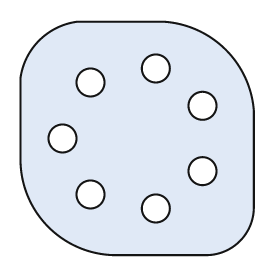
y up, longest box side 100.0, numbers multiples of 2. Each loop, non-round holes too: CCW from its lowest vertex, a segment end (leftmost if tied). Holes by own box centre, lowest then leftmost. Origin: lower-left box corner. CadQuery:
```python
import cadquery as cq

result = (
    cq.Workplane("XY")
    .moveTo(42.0, 0.0)
    .lineTo(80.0, 0.0)
    .threePointArc((94.0, 6.0), (100.0, 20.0))
    .lineTo(100.0, 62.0)
    .threePointArc((88.0, 88.0), (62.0, 100.0))
    .lineTo(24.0, 100.0)
    .threePointArc((8.0, 92.0), (0.0, 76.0))
    .lineTo(0.0, 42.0)
    .threePointArc((12.0, 12.0), (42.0, 0.0))
    .close()
    .moveTo(58.0, 20.0)
    .circle(6.0)
    .moveTo(30.0, 26.0)
    .circle(6.0)
    .moveTo(78.0, 36.0)
    .circle(6.0)
    .moveTo(18.0, 50.0)
    .circle(6.0)
    .moveTo(78.0, 64.0)
    .circle(6.0)
    .moveTo(30.0, 74.0)
    .circle(6.0)
    .moveTo(58.0, 80.0)
    .circle(6.0)
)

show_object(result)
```